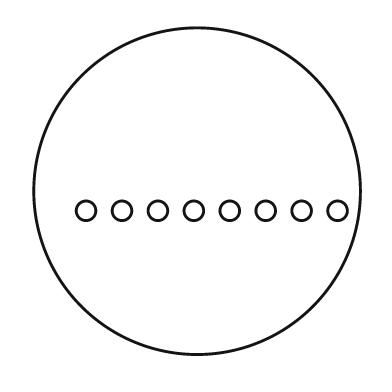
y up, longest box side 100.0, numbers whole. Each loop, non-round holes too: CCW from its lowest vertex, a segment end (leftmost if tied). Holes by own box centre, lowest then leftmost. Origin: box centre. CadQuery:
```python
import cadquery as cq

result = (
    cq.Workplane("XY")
    .moveTo(0.0, 0.0)
    .circle(50.0)
    .moveTo(-34.0, -6.0)
    .circle(3.0)
    .moveTo(-23.0, -6.0)
    .circle(3.0)
    .moveTo(-12.0, -6.0)
    .circle(3.0)
    .moveTo(-1.0, -6.0)
    .circle(3.0)
    .moveTo(10.0, -6.0)
    .circle(3.0)
    .moveTo(21.0, -6.0)
    .circle(3.0)
    .moveTo(32.0, -6.0)
    .circle(3.0)
    .moveTo(43.0, -6.0)
    .circle(3.0)
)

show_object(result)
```